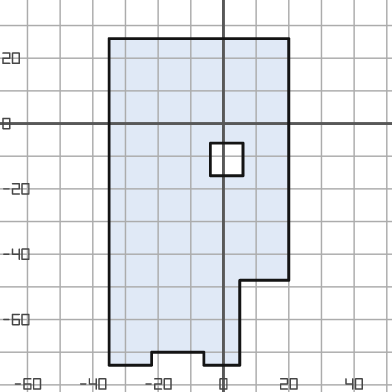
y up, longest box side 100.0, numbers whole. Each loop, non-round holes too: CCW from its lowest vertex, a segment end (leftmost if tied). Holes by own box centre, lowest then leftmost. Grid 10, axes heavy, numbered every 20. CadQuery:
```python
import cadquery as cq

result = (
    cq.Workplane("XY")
    .moveTo(-35.0, -74.0)
    .lineTo(-22.0, -74.0)
    .lineTo(-22.0, -70.0)
    .lineTo(-6.0, -70.0)
    .lineTo(-6.0, -74.0)
    .lineTo(5.0, -74.0)
    .lineTo(5.0, -48.0)
    .lineTo(20.0, -48.0)
    .lineTo(20.0, 26.0)
    .lineTo(-35.0, 26.0)
    .close()
    .moveTo(-4.0, -16.0)
    .lineTo(6.0, -16.0)
    .lineTo(6.0, -6.0)
    .lineTo(-4.0, -6.0)
    .close()
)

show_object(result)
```